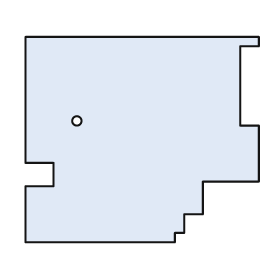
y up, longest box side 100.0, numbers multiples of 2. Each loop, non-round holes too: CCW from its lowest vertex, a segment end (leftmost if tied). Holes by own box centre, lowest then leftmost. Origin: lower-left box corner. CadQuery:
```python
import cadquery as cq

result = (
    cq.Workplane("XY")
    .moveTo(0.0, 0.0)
    .lineTo(64.0, 0.0)
    .lineTo(64.0, 4.0)
    .lineTo(68.0, 4.0)
    .lineTo(68.0, 12.0)
    .lineTo(76.0, 12.0)
    .lineTo(76.0, 26.0)
    .lineTo(100.0, 26.0)
    .lineTo(100.0, 50.0)
    .lineTo(92.0, 50.0)
    .lineTo(92.0, 84.0)
    .lineTo(100.0, 84.0)
    .lineTo(100.0, 88.0)
    .lineTo(0.0, 88.0)
    .lineTo(0.0, 34.0)
    .lineTo(12.0, 34.0)
    .lineTo(12.0, 24.0)
    .lineTo(0.0, 24.0)
    .close()
    .moveTo(22.0, 52.0)
    .circle(2.0)
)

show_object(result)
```